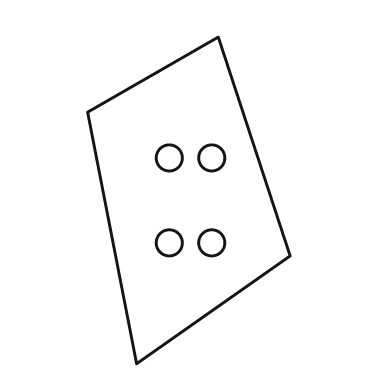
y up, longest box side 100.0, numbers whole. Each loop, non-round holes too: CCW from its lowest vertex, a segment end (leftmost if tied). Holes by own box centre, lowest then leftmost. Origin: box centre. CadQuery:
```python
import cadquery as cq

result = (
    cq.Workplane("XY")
    .moveTo(-16.0, -50.0)
    .lineTo(31.0, -17.0)
    .lineTo(9.0, 50.0)
    .lineTo(-31.0, 27.0)
    .close()
    .moveTo(-6.0, -13.0)
    .circle(4.0)
    .moveTo(7.0, -13.0)
    .circle(4.0)
    .moveTo(-6.0, 13.0)
    .circle(4.0)
    .moveTo(7.0, 13.0)
    .circle(4.0)
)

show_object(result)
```